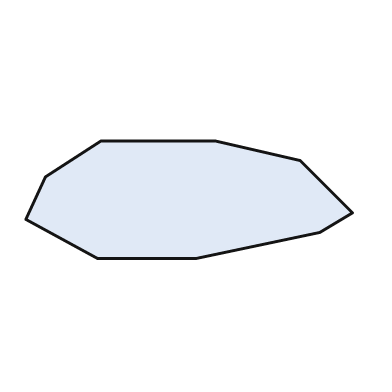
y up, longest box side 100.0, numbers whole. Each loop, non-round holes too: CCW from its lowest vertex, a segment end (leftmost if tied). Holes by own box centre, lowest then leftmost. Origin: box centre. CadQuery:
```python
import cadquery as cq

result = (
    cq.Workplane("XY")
    .moveTo(-28.0, -18.0)
    .lineTo(2.0, -18.0)
    .lineTo(40.0, -10.0)
    .lineTo(50.0, -4.0)
    .lineTo(34.0, 12.0)
    .lineTo(8.0, 18.0)
    .lineTo(-27.0, 18.0)
    .lineTo(-44.0, 7.0)
    .lineTo(-50.0, -6.0)
    .close()
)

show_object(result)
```